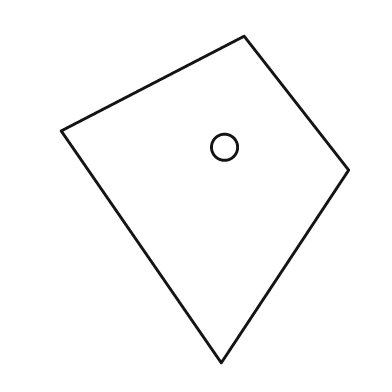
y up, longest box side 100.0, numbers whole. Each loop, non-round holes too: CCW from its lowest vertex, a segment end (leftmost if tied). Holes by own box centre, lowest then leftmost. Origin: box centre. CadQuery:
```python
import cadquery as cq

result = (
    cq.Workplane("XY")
    .moveTo(5.0, -50.0)
    .lineTo(44.0, 9.0)
    .lineTo(12.0, 50.0)
    .lineTo(-44.0, 21.0)
    .close()
    .moveTo(6.0, 16.0)
    .circle(4.0)
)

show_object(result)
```